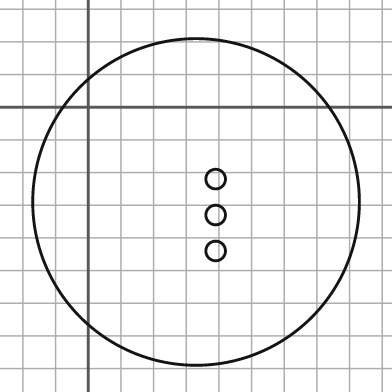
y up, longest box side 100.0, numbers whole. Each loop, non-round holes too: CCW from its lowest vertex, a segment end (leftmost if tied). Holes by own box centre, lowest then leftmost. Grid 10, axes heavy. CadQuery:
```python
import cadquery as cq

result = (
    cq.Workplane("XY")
    .moveTo(33.0, -29.0)
    .circle(50.0)
    .moveTo(39.0, -44.0)
    .circle(3.0)
    .moveTo(39.0, -33.0)
    .circle(3.0)
    .moveTo(39.0, -22.0)
    .circle(3.0)
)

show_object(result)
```